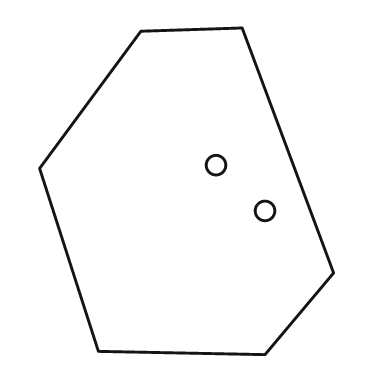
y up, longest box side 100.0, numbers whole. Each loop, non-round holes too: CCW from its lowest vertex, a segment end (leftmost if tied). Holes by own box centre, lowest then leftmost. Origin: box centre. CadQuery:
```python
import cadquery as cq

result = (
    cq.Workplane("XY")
    .moveTo(24.0, -50.0)
    .lineTo(45.0, -25.0)
    .lineTo(17.0, 50.0)
    .lineTo(-14.0, 49.0)
    .lineTo(-45.0, 7.0)
    .lineTo(-27.0, -49.0)
    .close()
    .moveTo(24.0, -6.0)
    .circle(3.0)
    .moveTo(9.0, 8.0)
    .circle(3.0)
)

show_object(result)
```